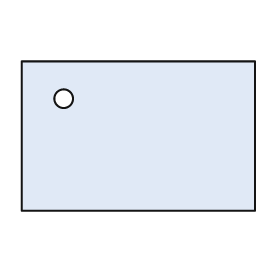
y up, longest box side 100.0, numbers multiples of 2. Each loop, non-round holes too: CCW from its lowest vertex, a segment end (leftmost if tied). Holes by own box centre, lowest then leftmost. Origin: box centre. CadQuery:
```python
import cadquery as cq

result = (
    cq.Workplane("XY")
    .moveTo(-50.0, -32.0)
    .lineTo(50.0, -32.0)
    .lineTo(50.0, 32.0)
    .lineTo(-50.0, 32.0)
    .close()
    .moveTo(-32.0, 16.0)
    .circle(4.0)
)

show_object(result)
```